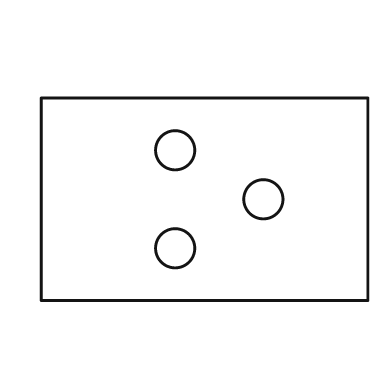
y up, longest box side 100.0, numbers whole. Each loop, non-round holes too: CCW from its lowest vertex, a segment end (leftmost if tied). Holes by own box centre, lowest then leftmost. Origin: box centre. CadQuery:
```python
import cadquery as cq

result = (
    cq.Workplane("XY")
    .moveTo(-50.0, -31.0)
    .lineTo(50.0, -31.0)
    .lineTo(50.0, 31.0)
    .lineTo(-50.0, 31.0)
    .close()
    .moveTo(-9.0, -15.0)
    .circle(6.0)
    .moveTo(18.0, 0.0)
    .circle(6.0)
    .moveTo(-9.0, 15.0)
    .circle(6.0)
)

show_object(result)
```